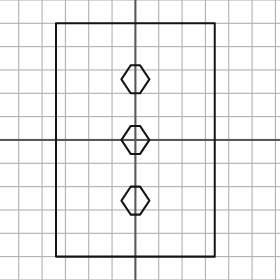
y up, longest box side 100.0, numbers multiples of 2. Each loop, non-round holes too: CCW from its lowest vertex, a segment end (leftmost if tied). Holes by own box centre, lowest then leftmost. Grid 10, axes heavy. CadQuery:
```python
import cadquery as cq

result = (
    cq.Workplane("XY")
    .moveTo(-34.0, -50.0)
    .lineTo(34.0, -50.0)
    .lineTo(34.0, 50.0)
    .lineTo(-34.0, 50.0)
    .close()
    .moveTo(-2.0, -32.0)
    .lineTo(2.0, -32.0)
    .lineTo(6.0, -26.0)
    .lineTo(2.0, -20.0)
    .lineTo(-2.0, -20.0)
    .lineTo(-6.0, -26.0)
    .close()
    .moveTo(-2.0, -6.0)
    .lineTo(2.0, -6.0)
    .lineTo(6.0, 0.0)
    .lineTo(2.0, 6.0)
    .lineTo(-2.0, 6.0)
    .lineTo(-6.0, 0.0)
    .close()
    .moveTo(-2.0, 20.0)
    .lineTo(2.0, 20.0)
    .lineTo(6.0, 26.0)
    .lineTo(2.0, 32.0)
    .lineTo(-2.0, 32.0)
    .lineTo(-6.0, 26.0)
    .close()
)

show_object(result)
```